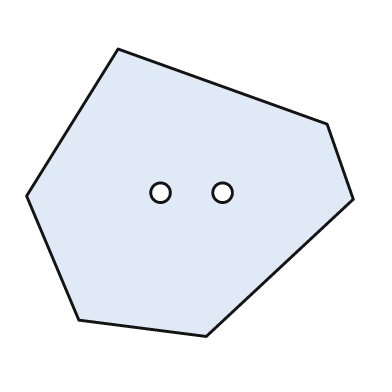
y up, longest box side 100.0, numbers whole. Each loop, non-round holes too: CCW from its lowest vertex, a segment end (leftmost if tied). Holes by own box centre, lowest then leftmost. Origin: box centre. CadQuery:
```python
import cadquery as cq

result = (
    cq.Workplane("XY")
    .moveTo(5.0, -44.0)
    .lineTo(50.0, -2.0)
    .lineTo(42.0, 21.0)
    .lineTo(-22.0, 44.0)
    .lineTo(-50.0, -1.0)
    .lineTo(-34.0, -39.0)
    .close()
    .moveTo(-9.0, 0.0)
    .circle(3.0)
    .moveTo(10.0, 0.0)
    .circle(3.0)
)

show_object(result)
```